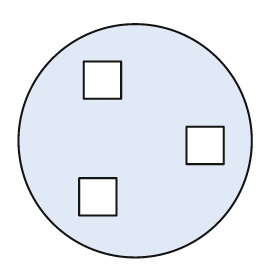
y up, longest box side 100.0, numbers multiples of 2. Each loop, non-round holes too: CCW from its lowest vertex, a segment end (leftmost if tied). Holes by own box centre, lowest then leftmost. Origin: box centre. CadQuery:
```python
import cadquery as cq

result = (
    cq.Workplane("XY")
    .moveTo(0.0, 0.0)
    .circle(50.0)
    .moveTo(-24.0, -32.0)
    .lineTo(-8.0, -32.0)
    .lineTo(-8.0, -16.0)
    .lineTo(-24.0, -16.0)
    .close()
    .moveTo(22.0, -10.0)
    .lineTo(38.0, -10.0)
    .lineTo(38.0, 6.0)
    .lineTo(22.0, 6.0)
    .close()
    .moveTo(-22.0, 18.0)
    .lineTo(-6.0, 18.0)
    .lineTo(-6.0, 34.0)
    .lineTo(-22.0, 34.0)
    .close()
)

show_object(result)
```